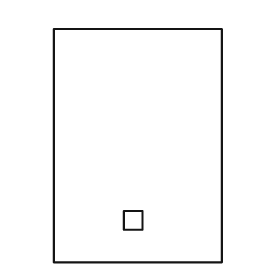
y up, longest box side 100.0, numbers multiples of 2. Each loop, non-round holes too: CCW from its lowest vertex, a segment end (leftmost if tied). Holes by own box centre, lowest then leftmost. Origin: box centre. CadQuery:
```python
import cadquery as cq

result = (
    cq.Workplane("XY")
    .moveTo(-36.0, -50.0)
    .lineTo(36.0, -50.0)
    .lineTo(36.0, 50.0)
    .lineTo(-36.0, 50.0)
    .close()
    .moveTo(-6.0, -36.0)
    .lineTo(2.0, -36.0)
    .lineTo(2.0, -28.0)
    .lineTo(-6.0, -28.0)
    .close()
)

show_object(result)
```